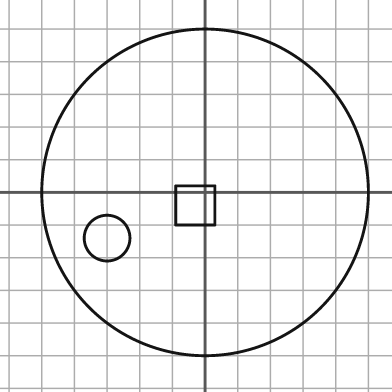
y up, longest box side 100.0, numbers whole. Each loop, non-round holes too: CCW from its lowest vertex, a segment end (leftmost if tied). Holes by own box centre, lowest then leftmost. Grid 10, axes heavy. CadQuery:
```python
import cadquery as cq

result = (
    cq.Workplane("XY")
    .moveTo(0.0, 0.0)
    .circle(50.0)
    .moveTo(-30.0, -14.0)
    .circle(7.0)
    .moveTo(-9.0, -10.0)
    .lineTo(3.0, -10.0)
    .lineTo(3.0, 2.0)
    .lineTo(-9.0, 2.0)
    .close()
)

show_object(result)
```